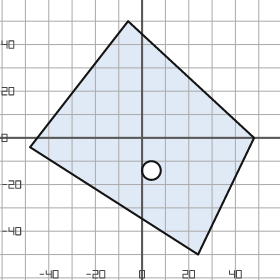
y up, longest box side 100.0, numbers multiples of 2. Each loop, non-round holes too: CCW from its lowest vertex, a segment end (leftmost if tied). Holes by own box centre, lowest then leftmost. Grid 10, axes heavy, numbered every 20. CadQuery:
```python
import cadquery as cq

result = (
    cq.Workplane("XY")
    .moveTo(24.0, -50.0)
    .lineTo(48.0, 0.0)
    .lineTo(-6.0, 50.0)
    .lineTo(-48.0, -4.0)
    .close()
    .moveTo(4.0, -14.0)
    .circle(4.0)
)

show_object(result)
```